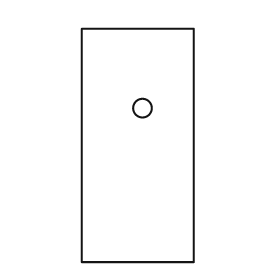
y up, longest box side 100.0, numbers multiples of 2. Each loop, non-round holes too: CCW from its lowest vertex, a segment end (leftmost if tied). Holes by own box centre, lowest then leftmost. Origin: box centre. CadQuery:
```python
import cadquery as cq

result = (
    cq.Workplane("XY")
    .moveTo(-24.0, -50.0)
    .lineTo(24.0, -50.0)
    .lineTo(24.0, 50.0)
    .lineTo(-24.0, 50.0)
    .close()
    .moveTo(2.0, 16.0)
    .circle(4.0)
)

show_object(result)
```